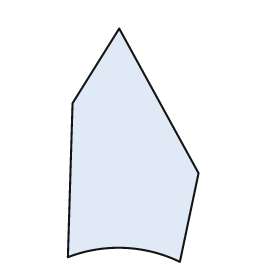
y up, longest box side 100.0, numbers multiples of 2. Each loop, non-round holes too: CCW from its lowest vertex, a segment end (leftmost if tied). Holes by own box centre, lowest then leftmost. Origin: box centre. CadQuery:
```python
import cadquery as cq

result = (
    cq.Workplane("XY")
    .moveTo(20.0, -50.0)
    .lineTo(28.0, -12.0)
    .lineTo(-6.0, 50.0)
    .lineTo(-26.0, 18.0)
    .lineTo(-28.0, -48.0)
    .threePointArc((-4.0, -44.0), (20.0, -50.0))
    .close()
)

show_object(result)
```